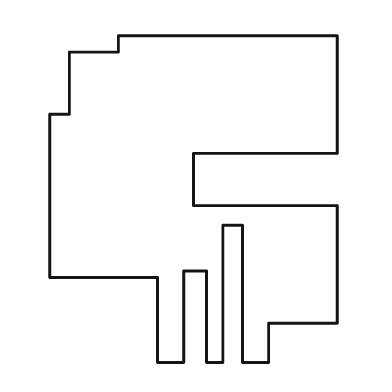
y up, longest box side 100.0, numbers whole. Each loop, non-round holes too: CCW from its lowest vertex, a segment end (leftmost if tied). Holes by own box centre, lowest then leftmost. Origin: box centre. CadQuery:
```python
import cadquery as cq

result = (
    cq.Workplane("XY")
    .moveTo(-11.0, -50.0)
    .lineTo(-3.0, -50.0)
    .lineTo(-3.0, -22.0)
    .lineTo(4.0, -22.0)
    .lineTo(4.0, -50.0)
    .lineTo(9.0, -50.0)
    .lineTo(9.0, -8.0)
    .lineTo(15.0, -8.0)
    .lineTo(15.0, -50.0)
    .lineTo(23.0, -50.0)
    .lineTo(23.0, -38.0)
    .lineTo(44.0, -38.0)
    .lineTo(44.0, -2.0)
    .lineTo(0.0, -2.0)
    .lineTo(0.0, 14.0)
    .lineTo(44.0, 14.0)
    .lineTo(44.0, 50.0)
    .lineTo(-23.0, 50.0)
    .lineTo(-23.0, 45.0)
    .lineTo(-38.0, 45.0)
    .lineTo(-38.0, 26.0)
    .lineTo(-44.0, 26.0)
    .lineTo(-44.0, -24.0)
    .lineTo(-11.0, -24.0)
    .close()
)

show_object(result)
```